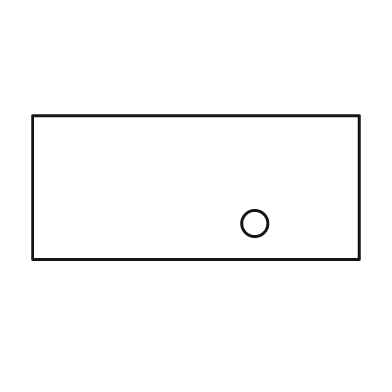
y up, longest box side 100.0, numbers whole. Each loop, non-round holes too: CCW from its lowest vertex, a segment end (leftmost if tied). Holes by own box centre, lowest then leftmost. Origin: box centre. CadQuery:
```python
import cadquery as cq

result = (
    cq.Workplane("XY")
    .moveTo(-50.0, -22.0)
    .lineTo(50.0, -22.0)
    .lineTo(50.0, 22.0)
    .lineTo(-50.0, 22.0)
    .close()
    .moveTo(18.0, -11.0)
    .circle(4.0)
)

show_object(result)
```